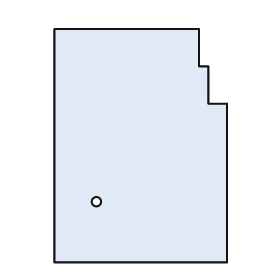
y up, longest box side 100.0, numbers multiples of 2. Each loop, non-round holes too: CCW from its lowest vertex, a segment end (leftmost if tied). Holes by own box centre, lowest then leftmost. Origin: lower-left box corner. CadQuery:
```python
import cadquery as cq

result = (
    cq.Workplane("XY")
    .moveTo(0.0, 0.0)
    .lineTo(74.0, 0.0)
    .lineTo(74.0, 68.0)
    .lineTo(66.0, 68.0)
    .lineTo(66.0, 84.0)
    .lineTo(62.0, 84.0)
    .lineTo(62.0, 100.0)
    .lineTo(0.0, 100.0)
    .close()
    .moveTo(18.0, 26.0)
    .circle(2.0)
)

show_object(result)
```